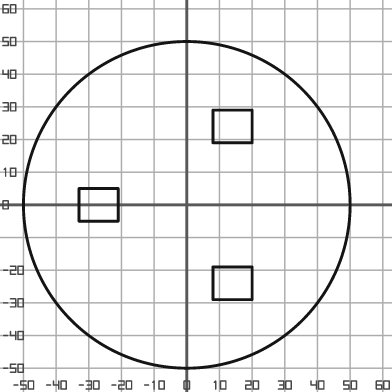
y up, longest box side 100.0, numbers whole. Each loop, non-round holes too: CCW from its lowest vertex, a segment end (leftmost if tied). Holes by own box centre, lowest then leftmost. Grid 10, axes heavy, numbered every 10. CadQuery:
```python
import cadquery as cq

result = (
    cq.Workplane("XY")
    .moveTo(0.0, 0.0)
    .circle(50.0)
    .moveTo(8.0, -29.0)
    .lineTo(20.0, -29.0)
    .lineTo(20.0, -19.0)
    .lineTo(8.0, -19.0)
    .close()
    .moveTo(-33.0, -5.0)
    .lineTo(-21.0, -5.0)
    .lineTo(-21.0, 5.0)
    .lineTo(-33.0, 5.0)
    .close()
    .moveTo(8.0, 19.0)
    .lineTo(20.0, 19.0)
    .lineTo(20.0, 29.0)
    .lineTo(8.0, 29.0)
    .close()
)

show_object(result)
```